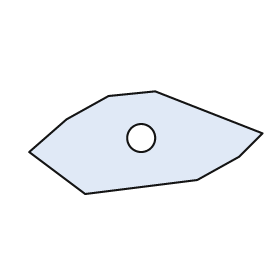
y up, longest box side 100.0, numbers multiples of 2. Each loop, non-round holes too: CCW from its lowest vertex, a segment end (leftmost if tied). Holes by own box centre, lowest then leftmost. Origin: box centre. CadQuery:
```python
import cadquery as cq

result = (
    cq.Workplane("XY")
    .moveTo(-26.0, -22.0)
    .lineTo(22.0, -16.0)
    .lineTo(40.0, -6.0)
    .lineTo(50.0, 4.0)
    .lineTo(4.0, 22.0)
    .lineTo(-16.0, 20.0)
    .lineTo(-34.0, 10.0)
    .lineTo(-50.0, -4.0)
    .close()
    .moveTo(-2.0, 2.0)
    .circle(6.0)
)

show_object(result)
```